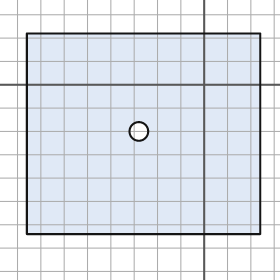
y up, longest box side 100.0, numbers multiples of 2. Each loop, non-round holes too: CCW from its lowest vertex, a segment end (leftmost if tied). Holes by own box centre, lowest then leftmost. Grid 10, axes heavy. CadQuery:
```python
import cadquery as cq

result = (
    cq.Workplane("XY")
    .moveTo(-76.0, -64.0)
    .lineTo(24.0, -64.0)
    .lineTo(24.0, 22.0)
    .lineTo(-76.0, 22.0)
    .close()
    .moveTo(-28.0, -20.0)
    .circle(4.0)
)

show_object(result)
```